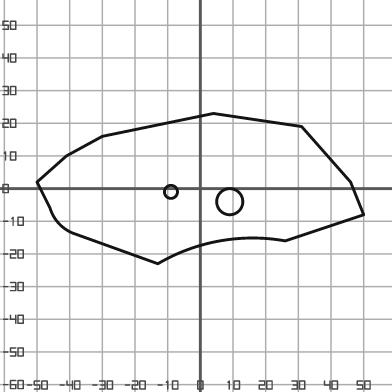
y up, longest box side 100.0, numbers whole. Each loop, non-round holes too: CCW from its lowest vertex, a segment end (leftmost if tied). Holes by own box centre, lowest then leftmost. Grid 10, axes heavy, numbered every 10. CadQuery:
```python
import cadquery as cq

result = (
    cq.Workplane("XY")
    .moveTo(-13.0, -23.0)
    .threePointArc((6.0, -16.0), (26.0, -16.0))
    .lineTo(50.0, -8.0)
    .lineTo(46.0, 2.0)
    .lineTo(31.0, 19.0)
    .lineTo(4.0, 23.0)
    .lineTo(-30.0, 16.0)
    .lineTo(-41.0, 10.0)
    .lineTo(-50.0, 2.0)
    .lineTo(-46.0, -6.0)
    .threePointArc((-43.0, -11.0), (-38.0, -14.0))
    .close()
    .moveTo(9.0, -4.0)
    .circle(4.0)
    .moveTo(-9.0, -1.0)
    .circle(2.0)
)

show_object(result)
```